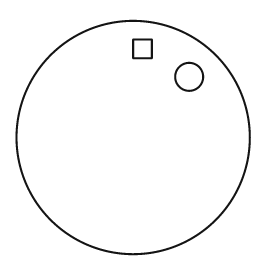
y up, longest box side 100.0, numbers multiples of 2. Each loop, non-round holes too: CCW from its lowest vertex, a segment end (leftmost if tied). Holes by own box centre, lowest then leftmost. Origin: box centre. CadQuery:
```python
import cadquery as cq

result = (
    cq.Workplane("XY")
    .moveTo(0.0, 0.0)
    .circle(50.0)
    .moveTo(24.0, 26.0)
    .circle(6.0)
    .moveTo(0.0, 34.0)
    .lineTo(8.0, 34.0)
    .lineTo(8.0, 42.0)
    .lineTo(0.0, 42.0)
    .close()
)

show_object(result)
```